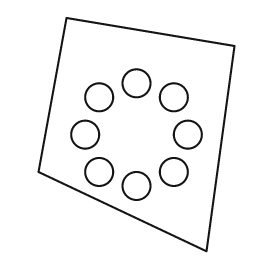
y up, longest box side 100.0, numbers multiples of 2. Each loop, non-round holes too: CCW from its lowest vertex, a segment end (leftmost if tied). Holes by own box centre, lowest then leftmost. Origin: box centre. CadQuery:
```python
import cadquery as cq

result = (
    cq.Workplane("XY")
    .moveTo(30.0, -50.0)
    .lineTo(42.0, 38.0)
    .lineTo(-30.0, 50.0)
    .lineTo(-42.0, -16.0)
    .close()
    .moveTo(0.0, -22.0)
    .circle(6.0)
    .moveTo(-16.0, -16.0)
    .circle(6.0)
    .moveTo(16.0, -16.0)
    .circle(6.0)
    .moveTo(-22.0, 0.0)
    .circle(6.0)
    .moveTo(22.0, 0.0)
    .circle(6.0)
    .moveTo(-16.0, 16.0)
    .circle(6.0)
    .moveTo(16.0, 16.0)
    .circle(6.0)
    .moveTo(0.0, 22.0)
    .circle(6.0)
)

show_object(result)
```